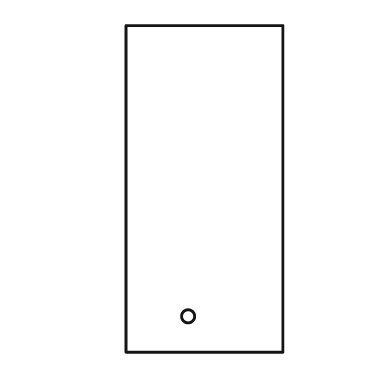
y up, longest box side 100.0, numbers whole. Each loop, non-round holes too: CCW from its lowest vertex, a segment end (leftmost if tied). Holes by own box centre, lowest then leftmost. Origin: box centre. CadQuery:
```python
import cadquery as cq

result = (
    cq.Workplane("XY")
    .moveTo(-24.0, -50.0)
    .lineTo(24.0, -50.0)
    .lineTo(24.0, 50.0)
    .lineTo(-24.0, 50.0)
    .close()
    .moveTo(-5.0, -39.0)
    .circle(2.0)
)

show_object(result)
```